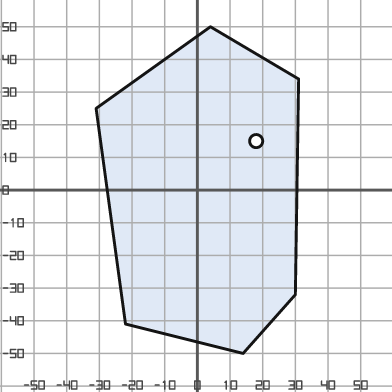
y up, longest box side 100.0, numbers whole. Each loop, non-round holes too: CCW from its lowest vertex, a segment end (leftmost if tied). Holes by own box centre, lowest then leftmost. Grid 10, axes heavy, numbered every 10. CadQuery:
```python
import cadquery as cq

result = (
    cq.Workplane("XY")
    .moveTo(14.0, -50.0)
    .lineTo(30.0, -32.0)
    .lineTo(31.0, 34.0)
    .lineTo(4.0, 50.0)
    .lineTo(-31.0, 25.0)
    .lineTo(-22.0, -41.0)
    .close()
    .moveTo(18.0, 15.0)
    .circle(2.0)
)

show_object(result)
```